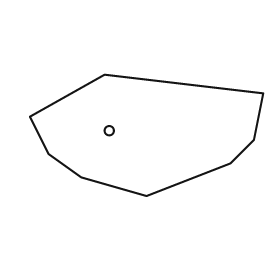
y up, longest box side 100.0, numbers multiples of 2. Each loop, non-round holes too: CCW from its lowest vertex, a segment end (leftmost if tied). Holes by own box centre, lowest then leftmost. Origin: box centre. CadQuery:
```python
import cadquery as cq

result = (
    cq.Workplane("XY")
    .moveTo(0.0, -26.0)
    .lineTo(36.0, -12.0)
    .lineTo(46.0, -2.0)
    .lineTo(50.0, 18.0)
    .lineTo(-18.0, 26.0)
    .lineTo(-50.0, 8.0)
    .lineTo(-42.0, -8.0)
    .lineTo(-28.0, -18.0)
    .close()
    .moveTo(-16.0, 2.0)
    .circle(2.0)
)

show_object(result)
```